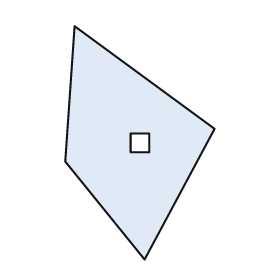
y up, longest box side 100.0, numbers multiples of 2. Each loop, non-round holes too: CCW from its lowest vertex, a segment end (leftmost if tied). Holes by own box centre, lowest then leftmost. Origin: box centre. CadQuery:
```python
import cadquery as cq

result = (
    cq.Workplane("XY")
    .moveTo(2.0, -50.0)
    .lineTo(32.0, 6.0)
    .lineTo(-28.0, 50.0)
    .lineTo(-32.0, -8.0)
    .close()
    .moveTo(-4.0, -4.0)
    .lineTo(4.0, -4.0)
    .lineTo(4.0, 4.0)
    .lineTo(-4.0, 4.0)
    .close()
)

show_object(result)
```